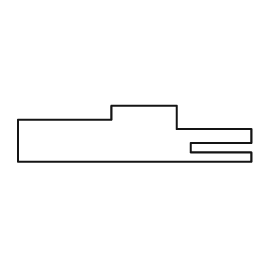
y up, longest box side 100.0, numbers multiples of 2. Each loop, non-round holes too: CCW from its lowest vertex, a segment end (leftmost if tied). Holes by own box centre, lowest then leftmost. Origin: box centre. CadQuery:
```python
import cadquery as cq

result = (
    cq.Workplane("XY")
    .moveTo(-50.0, -12.0)
    .lineTo(50.0, -12.0)
    .lineTo(50.0, -8.0)
    .lineTo(24.0, -8.0)
    .lineTo(24.0, -4.0)
    .lineTo(50.0, -4.0)
    .lineTo(50.0, 2.0)
    .lineTo(18.0, 2.0)
    .lineTo(18.0, 12.0)
    .lineTo(-10.0, 12.0)
    .lineTo(-10.0, 6.0)
    .lineTo(-50.0, 6.0)
    .close()
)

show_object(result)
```